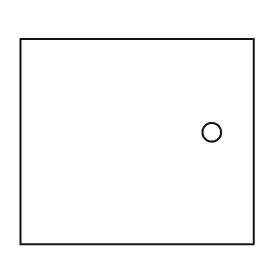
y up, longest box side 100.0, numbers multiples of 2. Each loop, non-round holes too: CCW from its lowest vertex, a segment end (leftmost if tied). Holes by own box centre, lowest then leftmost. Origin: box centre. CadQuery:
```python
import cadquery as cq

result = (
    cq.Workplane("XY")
    .moveTo(-50.0, -44.0)
    .lineTo(50.0, -44.0)
    .lineTo(50.0, 44.0)
    .lineTo(-50.0, 44.0)
    .close()
    .moveTo(32.0, 4.0)
    .circle(4.0)
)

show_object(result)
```